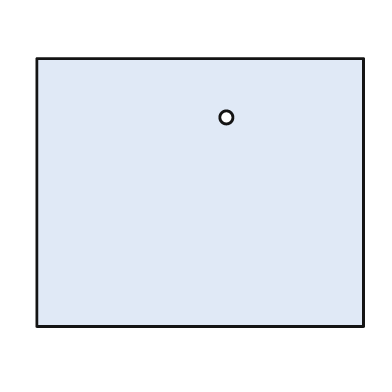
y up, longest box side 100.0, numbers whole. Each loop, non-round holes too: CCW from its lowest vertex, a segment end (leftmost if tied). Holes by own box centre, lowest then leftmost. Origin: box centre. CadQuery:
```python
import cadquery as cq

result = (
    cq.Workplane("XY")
    .moveTo(-50.0, -41.0)
    .lineTo(50.0, -41.0)
    .lineTo(50.0, 41.0)
    .lineTo(-50.0, 41.0)
    .close()
    .moveTo(8.0, 23.0)
    .circle(2.0)
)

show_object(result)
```